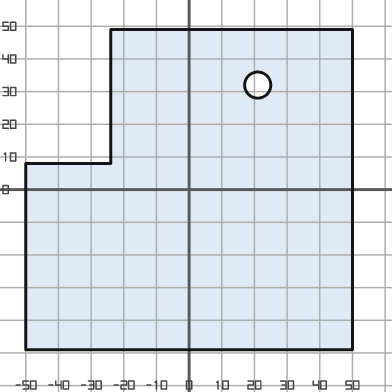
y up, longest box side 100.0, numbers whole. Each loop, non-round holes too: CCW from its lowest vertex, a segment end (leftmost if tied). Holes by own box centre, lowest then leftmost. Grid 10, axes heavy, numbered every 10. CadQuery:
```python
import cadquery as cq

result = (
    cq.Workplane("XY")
    .moveTo(-50.0, -49.0)
    .lineTo(50.0, -49.0)
    .lineTo(50.0, 49.0)
    .lineTo(-24.0, 49.0)
    .lineTo(-24.0, 8.0)
    .lineTo(-50.0, 8.0)
    .close()
    .moveTo(21.0, 32.0)
    .circle(4.0)
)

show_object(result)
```